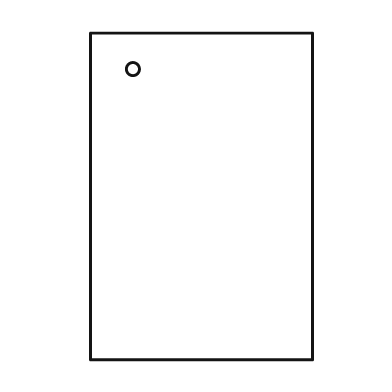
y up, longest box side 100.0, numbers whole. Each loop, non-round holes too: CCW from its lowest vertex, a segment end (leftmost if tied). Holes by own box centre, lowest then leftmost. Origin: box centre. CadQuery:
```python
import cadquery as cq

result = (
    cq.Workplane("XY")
    .moveTo(-34.0, -50.0)
    .lineTo(34.0, -50.0)
    .lineTo(34.0, 50.0)
    .lineTo(-34.0, 50.0)
    .close()
    .moveTo(-21.0, 39.0)
    .circle(2.0)
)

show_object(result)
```